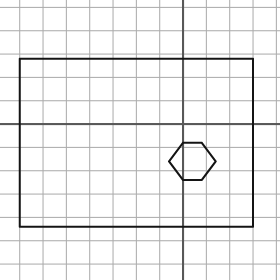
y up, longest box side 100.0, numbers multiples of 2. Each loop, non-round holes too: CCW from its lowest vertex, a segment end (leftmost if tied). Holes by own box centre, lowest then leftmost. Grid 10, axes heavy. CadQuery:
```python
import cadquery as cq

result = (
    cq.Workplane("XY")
    .moveTo(-70.0, -44.0)
    .lineTo(30.0, -44.0)
    .lineTo(30.0, 28.0)
    .lineTo(-70.0, 28.0)
    .close()
    .moveTo(0.0, -24.0)
    .lineTo(8.0, -24.0)
    .lineTo(14.0, -16.0)
    .lineTo(8.0, -8.0)
    .lineTo(0.0, -8.0)
    .lineTo(-6.0, -16.0)
    .close()
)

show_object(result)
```